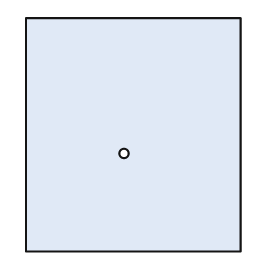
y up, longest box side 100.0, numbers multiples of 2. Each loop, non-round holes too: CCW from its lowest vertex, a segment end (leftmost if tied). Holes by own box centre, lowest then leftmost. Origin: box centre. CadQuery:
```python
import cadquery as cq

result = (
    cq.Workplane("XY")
    .moveTo(-46.0, -50.0)
    .lineTo(46.0, -50.0)
    .lineTo(46.0, 50.0)
    .lineTo(-46.0, 50.0)
    .close()
    .moveTo(-4.0, -8.0)
    .circle(2.0)
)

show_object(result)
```